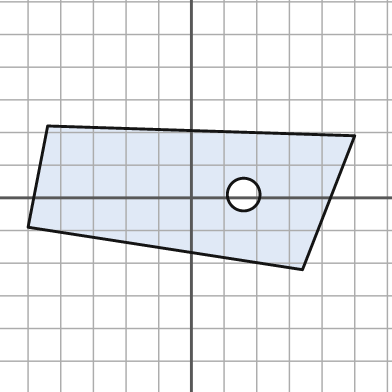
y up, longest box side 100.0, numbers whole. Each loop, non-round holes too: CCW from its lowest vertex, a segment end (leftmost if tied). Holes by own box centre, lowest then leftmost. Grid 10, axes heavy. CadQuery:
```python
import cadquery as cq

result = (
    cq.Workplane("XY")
    .moveTo(34.0, -22.0)
    .lineTo(50.0, 19.0)
    .lineTo(-44.0, 22.0)
    .lineTo(-50.0, -9.0)
    .close()
    .moveTo(16.0, 1.0)
    .circle(5.0)
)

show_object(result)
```